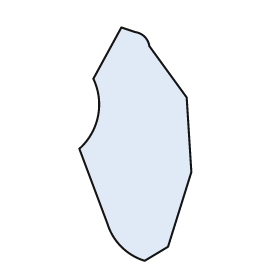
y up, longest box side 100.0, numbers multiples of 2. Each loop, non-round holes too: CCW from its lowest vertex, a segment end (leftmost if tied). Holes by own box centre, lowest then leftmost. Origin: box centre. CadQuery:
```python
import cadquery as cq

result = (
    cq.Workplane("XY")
    .moveTo(4.0, -50.0)
    .lineTo(14.0, -44.0)
    .lineTo(24.0, -12.0)
    .lineTo(22.0, 20.0)
    .lineTo(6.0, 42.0)
    .threePointArc((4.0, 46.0), (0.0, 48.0))
    .lineTo(-6.0, 50.0)
    .lineTo(-18.0, 28.0)
    .threePointArc((-16.0, 12.0), (-24.0, -2.0))
    .lineTo(-12.0, -34.0)
    .threePointArc((-6.0, -44.0), (4.0, -50.0))
    .close()
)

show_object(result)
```